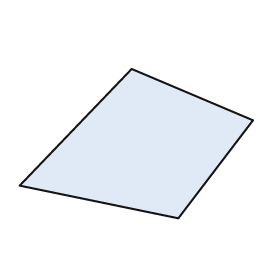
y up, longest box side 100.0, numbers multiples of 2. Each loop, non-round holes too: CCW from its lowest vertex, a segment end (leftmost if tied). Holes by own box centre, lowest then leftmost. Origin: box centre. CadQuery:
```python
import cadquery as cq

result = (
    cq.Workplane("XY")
    .moveTo(18.0, -32.0)
    .lineTo(50.0, 10.0)
    .lineTo(-2.0, 32.0)
    .lineTo(-50.0, -18.0)
    .close()
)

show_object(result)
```